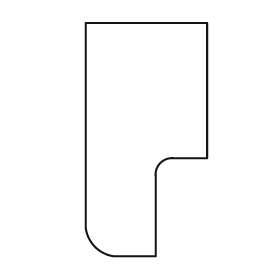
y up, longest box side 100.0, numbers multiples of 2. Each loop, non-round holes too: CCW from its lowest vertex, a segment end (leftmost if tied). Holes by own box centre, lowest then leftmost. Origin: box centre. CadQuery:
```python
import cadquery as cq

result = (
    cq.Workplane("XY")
    .moveTo(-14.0, -50.0)
    .lineTo(4.0, -50.0)
    .lineTo(4.0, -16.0)
    .threePointArc((6.0, -10.0), (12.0, -8.0))
    .lineTo(26.0, -8.0)
    .lineTo(26.0, 50.0)
    .lineTo(-26.0, 50.0)
    .lineTo(-26.0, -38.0)
    .threePointArc((-22.0, -46.0), (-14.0, -50.0))
    .close()
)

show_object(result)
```